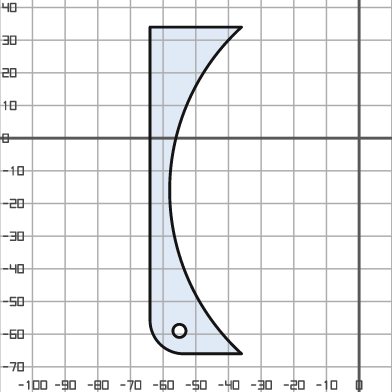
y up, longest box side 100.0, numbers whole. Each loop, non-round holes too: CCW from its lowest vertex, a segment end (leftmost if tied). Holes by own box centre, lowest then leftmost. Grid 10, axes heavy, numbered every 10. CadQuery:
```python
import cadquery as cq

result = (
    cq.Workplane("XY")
    .moveTo(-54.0, -66.0)
    .lineTo(-36.0, -66.0)
    .threePointArc((-58.0, -16.0), (-36.0, 34.0))
    .lineTo(-64.0, 34.0)
    .lineTo(-64.0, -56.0)
    .threePointArc((-61.0, -63.0), (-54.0, -66.0))
    .close()
    .moveTo(-55.0, -59.0)
    .circle(2.0)
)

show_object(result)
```